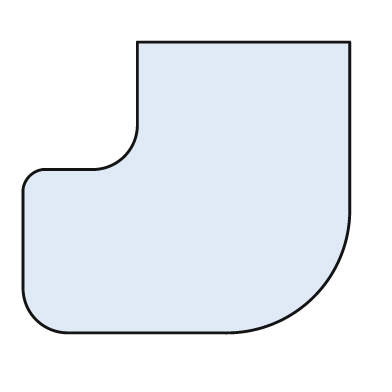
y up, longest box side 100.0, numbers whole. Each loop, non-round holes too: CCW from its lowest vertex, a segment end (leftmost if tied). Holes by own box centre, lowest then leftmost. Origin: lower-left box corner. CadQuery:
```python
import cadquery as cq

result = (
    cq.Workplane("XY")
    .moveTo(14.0, 0.0)
    .lineTo(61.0, 0.0)
    .threePointArc((89.0, 11.0), (100.0, 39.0))
    .lineTo(100.0, 89.0)
    .lineTo(35.0, 89.0)
    .lineTo(35.0, 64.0)
    .threePointArc((31.0, 54.0), (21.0, 50.0))
    .lineTo(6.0, 50.0)
    .threePointArc((2.0, 48.0), (0.0, 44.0))
    .lineTo(0.0, 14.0)
    .threePointArc((4.0, 4.0), (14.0, 0.0))
    .close()
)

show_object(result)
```